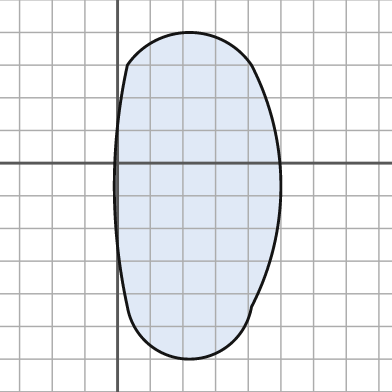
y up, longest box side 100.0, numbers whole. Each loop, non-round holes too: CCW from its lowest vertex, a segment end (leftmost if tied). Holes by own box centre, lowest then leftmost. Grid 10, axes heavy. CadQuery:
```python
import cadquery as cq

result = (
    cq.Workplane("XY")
    .moveTo(3.0, -44.0)
    .threePointArc((22.0, -60.0), (41.0, -44.0))
    .threePointArc((50.0, -7.0), (41.0, 30.0))
    .threePointArc((22.0, 40.0), (3.0, 30.0))
    .threePointArc((-1.0, -7.0), (3.0, -44.0))
    .close()
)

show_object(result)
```